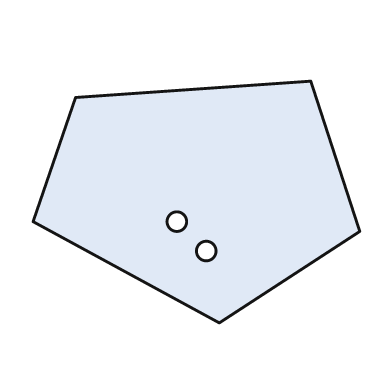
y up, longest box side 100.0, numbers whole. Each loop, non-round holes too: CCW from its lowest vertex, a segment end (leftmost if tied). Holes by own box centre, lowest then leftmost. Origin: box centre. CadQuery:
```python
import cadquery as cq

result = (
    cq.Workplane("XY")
    .moveTo(7.0, -37.0)
    .lineTo(50.0, -9.0)
    .lineTo(35.0, 37.0)
    .lineTo(-37.0, 32.0)
    .lineTo(-50.0, -6.0)
    .close()
    .moveTo(3.0, -15.0)
    .circle(3.0)
    .moveTo(-6.0, -6.0)
    .circle(3.0)
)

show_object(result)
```